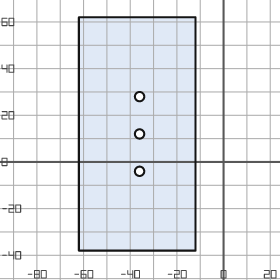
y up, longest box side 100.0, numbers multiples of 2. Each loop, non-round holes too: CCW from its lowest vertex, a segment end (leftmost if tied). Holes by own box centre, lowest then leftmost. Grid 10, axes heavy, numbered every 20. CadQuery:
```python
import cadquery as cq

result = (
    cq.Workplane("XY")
    .moveTo(-62.0, -38.0)
    .lineTo(-12.0, -38.0)
    .lineTo(-12.0, 62.0)
    .lineTo(-62.0, 62.0)
    .close()
    .moveTo(-36.0, -4.0)
    .circle(2.0)
    .moveTo(-36.0, 12.0)
    .circle(2.0)
    .moveTo(-36.0, 28.0)
    .circle(2.0)
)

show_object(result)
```